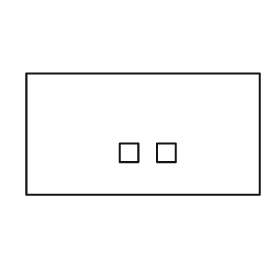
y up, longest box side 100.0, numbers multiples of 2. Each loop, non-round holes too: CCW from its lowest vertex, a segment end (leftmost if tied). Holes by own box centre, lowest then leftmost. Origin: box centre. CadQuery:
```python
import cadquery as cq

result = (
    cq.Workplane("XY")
    .moveTo(-50.0, -26.0)
    .lineTo(50.0, -26.0)
    .lineTo(50.0, 26.0)
    .lineTo(-50.0, 26.0)
    .close()
    .moveTo(-10.0, -12.0)
    .lineTo(-2.0, -12.0)
    .lineTo(-2.0, -4.0)
    .lineTo(-10.0, -4.0)
    .close()
    .moveTo(6.0, -12.0)
    .lineTo(14.0, -12.0)
    .lineTo(14.0, -4.0)
    .lineTo(6.0, -4.0)
    .close()
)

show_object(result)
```